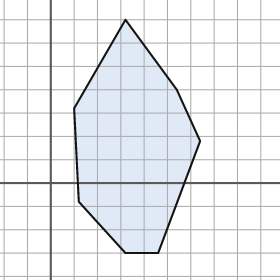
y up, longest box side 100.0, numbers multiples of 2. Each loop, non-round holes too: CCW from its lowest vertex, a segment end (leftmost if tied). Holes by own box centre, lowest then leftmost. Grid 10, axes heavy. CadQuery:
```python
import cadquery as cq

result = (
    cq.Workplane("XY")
    .moveTo(32.0, -30.0)
    .lineTo(46.0, -30.0)
    .lineTo(64.0, 18.0)
    .lineTo(54.0, 40.0)
    .lineTo(32.0, 70.0)
    .lineTo(10.0, 32.0)
    .lineTo(12.0, -8.0)
    .close()
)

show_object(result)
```